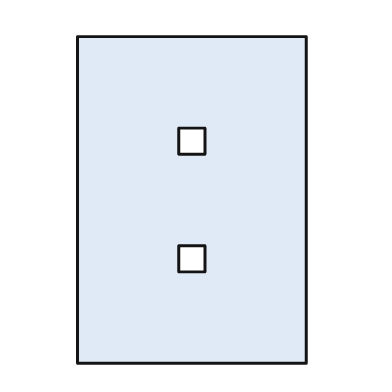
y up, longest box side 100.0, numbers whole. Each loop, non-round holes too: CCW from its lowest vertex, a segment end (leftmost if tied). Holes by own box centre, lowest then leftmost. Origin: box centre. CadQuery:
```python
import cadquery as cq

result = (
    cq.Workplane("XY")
    .moveTo(-35.0, -50.0)
    .lineTo(35.0, -50.0)
    .lineTo(35.0, 50.0)
    .lineTo(-35.0, 50.0)
    .close()
    .moveTo(-4.0, -22.0)
    .lineTo(4.0, -22.0)
    .lineTo(4.0, -14.0)
    .lineTo(-4.0, -14.0)
    .close()
    .moveTo(-4.0, 14.0)
    .lineTo(4.0, 14.0)
    .lineTo(4.0, 22.0)
    .lineTo(-4.0, 22.0)
    .close()
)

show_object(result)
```